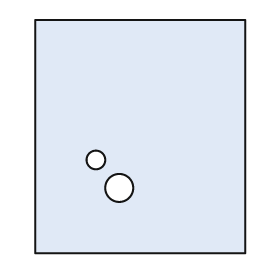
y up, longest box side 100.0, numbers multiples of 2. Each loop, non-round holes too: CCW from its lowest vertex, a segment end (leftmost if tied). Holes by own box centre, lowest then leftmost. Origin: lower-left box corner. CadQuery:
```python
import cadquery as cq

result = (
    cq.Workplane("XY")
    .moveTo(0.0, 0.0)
    .lineTo(90.0, 0.0)
    .lineTo(90.0, 100.0)
    .lineTo(0.0, 100.0)
    .close()
    .moveTo(36.0, 28.0)
    .circle(6.0)
    .moveTo(26.0, 40.0)
    .circle(4.0)
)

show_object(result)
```